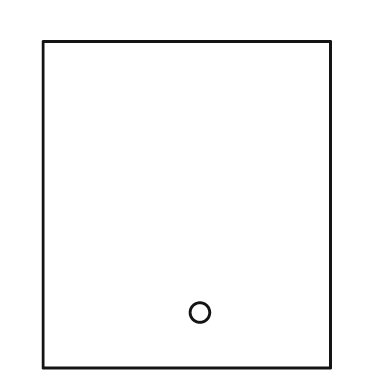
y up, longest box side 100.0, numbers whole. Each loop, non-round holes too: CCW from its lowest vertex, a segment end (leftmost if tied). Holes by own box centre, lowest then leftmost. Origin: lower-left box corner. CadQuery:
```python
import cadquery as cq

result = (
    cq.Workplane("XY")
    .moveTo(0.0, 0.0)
    .lineTo(88.0, 0.0)
    .lineTo(88.0, 100.0)
    .lineTo(0.0, 100.0)
    .close()
    .moveTo(48.0, 17.0)
    .circle(3.0)
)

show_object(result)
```